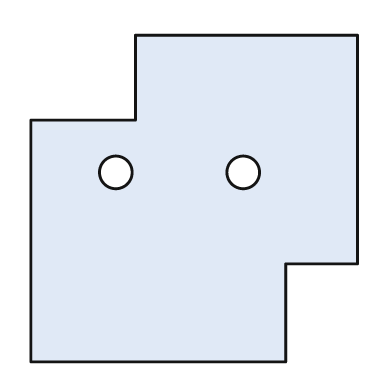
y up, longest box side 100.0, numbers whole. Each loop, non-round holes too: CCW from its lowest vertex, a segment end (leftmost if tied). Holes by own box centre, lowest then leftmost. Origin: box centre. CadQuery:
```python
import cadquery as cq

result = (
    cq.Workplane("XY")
    .moveTo(-50.0, -50.0)
    .lineTo(28.0, -50.0)
    .lineTo(28.0, -20.0)
    .lineTo(50.0, -20.0)
    .lineTo(50.0, 50.0)
    .lineTo(-18.0, 50.0)
    .lineTo(-18.0, 24.0)
    .lineTo(-50.0, 24.0)
    .close()
    .moveTo(-24.0, 8.0)
    .circle(5.0)
    .moveTo(15.0, 8.0)
    .circle(5.0)
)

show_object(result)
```